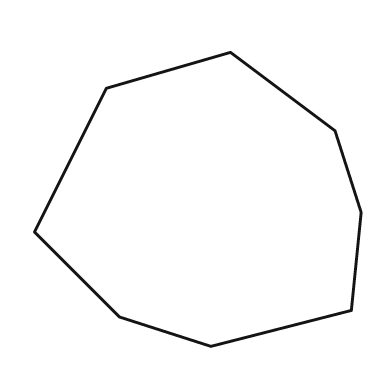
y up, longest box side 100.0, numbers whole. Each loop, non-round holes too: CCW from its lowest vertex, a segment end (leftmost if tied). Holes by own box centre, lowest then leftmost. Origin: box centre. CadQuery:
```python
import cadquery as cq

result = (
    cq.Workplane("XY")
    .moveTo(4.0, -45.0)
    .lineTo(47.0, -34.0)
    .lineTo(50.0, -4.0)
    .lineTo(42.0, 21.0)
    .lineTo(10.0, 45.0)
    .lineTo(-28.0, 34.0)
    .lineTo(-50.0, -10.0)
    .lineTo(-24.0, -36.0)
    .close()
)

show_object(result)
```